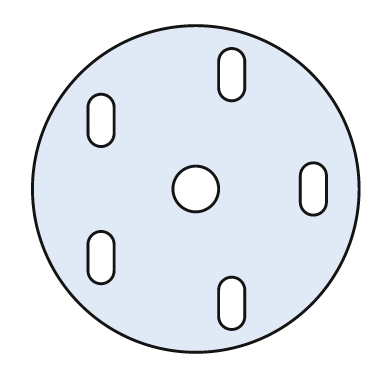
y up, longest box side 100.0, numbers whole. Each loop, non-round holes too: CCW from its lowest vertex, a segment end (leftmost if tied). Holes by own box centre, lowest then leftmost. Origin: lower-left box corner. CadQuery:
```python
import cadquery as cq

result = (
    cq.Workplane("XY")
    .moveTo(50.0, 50.0)
    .circle(50.0)
    .moveTo(57.0, 11.0)
    .threePointArc((61.0, 7.0), (65.0, 11.0))
    .lineTo(65.0, 19.0)
    .threePointArc((61.0, 23.0), (57.0, 19.0))
    .close()
    .moveTo(17.0, 25.0)
    .threePointArc((21.0, 21.0), (25.0, 25.0))
    .lineTo(25.0, 33.0)
    .threePointArc((21.0, 37.0), (17.0, 33.0))
    .close()
    .moveTo(50.0, 50.0)
    .circle(7.0)
    .moveTo(82.0, 46.0)
    .threePointArc((86.0, 42.0), (90.0, 46.0))
    .lineTo(90.0, 54.0)
    .threePointArc((86.0, 58.0), (82.0, 54.0))
    .close()
    .moveTo(17.0, 67.0)
    .threePointArc((21.0, 63.0), (25.0, 67.0))
    .lineTo(25.0, 75.0)
    .threePointArc((21.0, 79.0), (17.0, 75.0))
    .close()
    .moveTo(57.0, 81.0)
    .threePointArc((61.0, 77.0), (65.0, 81.0))
    .lineTo(65.0, 89.0)
    .threePointArc((61.0, 93.0), (57.0, 89.0))
    .close()
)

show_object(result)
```